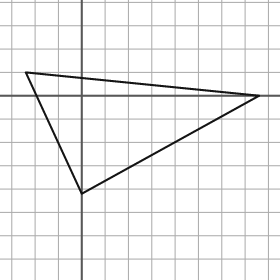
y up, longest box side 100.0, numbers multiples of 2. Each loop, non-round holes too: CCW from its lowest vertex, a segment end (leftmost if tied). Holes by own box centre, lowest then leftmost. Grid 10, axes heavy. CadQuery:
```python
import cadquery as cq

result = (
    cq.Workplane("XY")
    .moveTo(0.0, -42.0)
    .lineTo(76.0, 0.0)
    .lineTo(-24.0, 10.0)
    .close()
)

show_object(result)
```